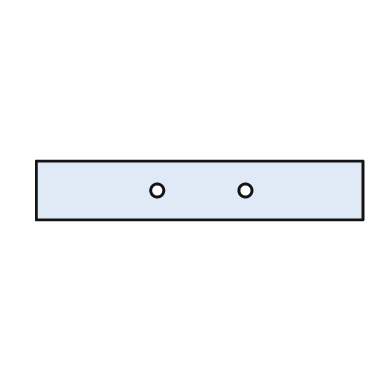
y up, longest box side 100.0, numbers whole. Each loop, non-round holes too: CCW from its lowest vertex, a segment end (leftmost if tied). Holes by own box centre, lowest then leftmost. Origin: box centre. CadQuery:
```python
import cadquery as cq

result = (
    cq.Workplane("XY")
    .moveTo(-50.0, -9.0)
    .lineTo(50.0, -9.0)
    .lineTo(50.0, 9.0)
    .lineTo(-50.0, 9.0)
    .close()
    .moveTo(-13.0, 0.0)
    .circle(2.0)
    .moveTo(14.0, 0.0)
    .circle(2.0)
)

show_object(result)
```